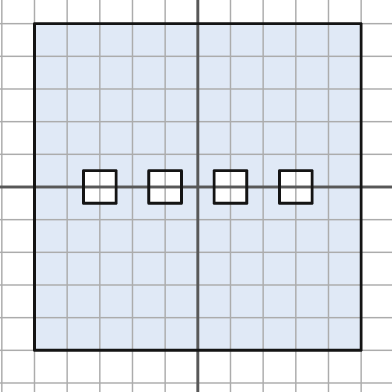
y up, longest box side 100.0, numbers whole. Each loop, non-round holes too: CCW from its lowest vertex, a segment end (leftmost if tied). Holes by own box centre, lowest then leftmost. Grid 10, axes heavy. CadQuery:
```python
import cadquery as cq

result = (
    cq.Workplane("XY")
    .moveTo(-50.0, -50.0)
    .lineTo(50.0, -50.0)
    .lineTo(50.0, 50.0)
    .lineTo(-50.0, 50.0)
    .close()
    .moveTo(-35.0, -5.0)
    .lineTo(-25.0, -5.0)
    .lineTo(-25.0, 5.0)
    .lineTo(-35.0, 5.0)
    .close()
    .moveTo(-15.0, -5.0)
    .lineTo(-5.0, -5.0)
    .lineTo(-5.0, 5.0)
    .lineTo(-15.0, 5.0)
    .close()
    .moveTo(5.0, -5.0)
    .lineTo(15.0, -5.0)
    .lineTo(15.0, 5.0)
    .lineTo(5.0, 5.0)
    .close()
    .moveTo(25.0, -5.0)
    .lineTo(35.0, -5.0)
    .lineTo(35.0, 5.0)
    .lineTo(25.0, 5.0)
    .close()
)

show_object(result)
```